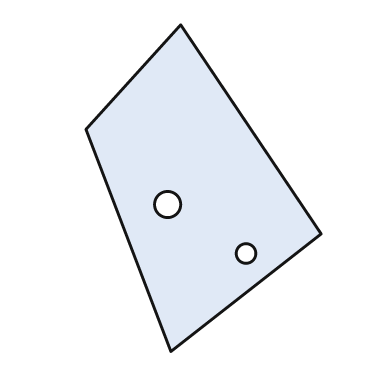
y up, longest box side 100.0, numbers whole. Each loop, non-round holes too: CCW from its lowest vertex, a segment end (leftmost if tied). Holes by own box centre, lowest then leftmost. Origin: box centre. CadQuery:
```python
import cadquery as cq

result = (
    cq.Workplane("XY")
    .moveTo(-10.0, -50.0)
    .lineTo(36.0, -14.0)
    .lineTo(-7.0, 50.0)
    .lineTo(-36.0, 18.0)
    .close()
    .moveTo(13.0, -20.0)
    .circle(3.0)
    .moveTo(-11.0, -5.0)
    .circle(4.0)
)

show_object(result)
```